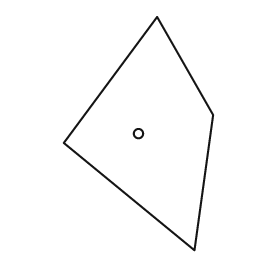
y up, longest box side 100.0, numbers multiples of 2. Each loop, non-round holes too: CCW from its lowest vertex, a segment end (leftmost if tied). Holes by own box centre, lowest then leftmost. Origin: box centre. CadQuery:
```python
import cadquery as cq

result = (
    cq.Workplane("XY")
    .moveTo(24.0, -50.0)
    .lineTo(32.0, 8.0)
    .lineTo(8.0, 50.0)
    .lineTo(-32.0, -4.0)
    .close()
    .moveTo(0.0, 0.0)
    .circle(2.0)
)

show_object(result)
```